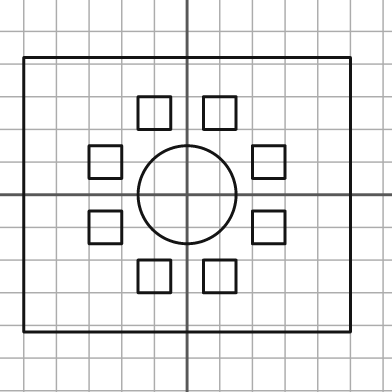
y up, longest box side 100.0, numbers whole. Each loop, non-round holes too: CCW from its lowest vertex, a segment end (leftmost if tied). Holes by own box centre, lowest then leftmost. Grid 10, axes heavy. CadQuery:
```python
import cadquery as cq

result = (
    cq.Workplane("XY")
    .moveTo(-50.0, -42.0)
    .lineTo(50.0, -42.0)
    .lineTo(50.0, 42.0)
    .lineTo(-50.0, 42.0)
    .close()
    .moveTo(-15.0, -30.0)
    .lineTo(-5.0, -30.0)
    .lineTo(-5.0, -20.0)
    .lineTo(-15.0, -20.0)
    .close()
    .moveTo(5.0, -30.0)
    .lineTo(15.0, -30.0)
    .lineTo(15.0, -20.0)
    .lineTo(5.0, -20.0)
    .close()
    .moveTo(-30.0, -15.0)
    .lineTo(-20.0, -15.0)
    .lineTo(-20.0, -5.0)
    .lineTo(-30.0, -5.0)
    .close()
    .moveTo(20.0, -15.0)
    .lineTo(30.0, -15.0)
    .lineTo(30.0, -5.0)
    .lineTo(20.0, -5.0)
    .close()
    .moveTo(0.0, 0.0)
    .circle(15.0)
    .moveTo(-30.0, 5.0)
    .lineTo(-20.0, 5.0)
    .lineTo(-20.0, 15.0)
    .lineTo(-30.0, 15.0)
    .close()
    .moveTo(20.0, 5.0)
    .lineTo(30.0, 5.0)
    .lineTo(30.0, 15.0)
    .lineTo(20.0, 15.0)
    .close()
    .moveTo(-15.0, 20.0)
    .lineTo(-5.0, 20.0)
    .lineTo(-5.0, 30.0)
    .lineTo(-15.0, 30.0)
    .close()
    .moveTo(5.0, 20.0)
    .lineTo(15.0, 20.0)
    .lineTo(15.0, 30.0)
    .lineTo(5.0, 30.0)
    .close()
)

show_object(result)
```